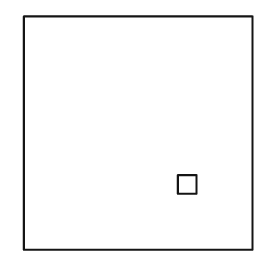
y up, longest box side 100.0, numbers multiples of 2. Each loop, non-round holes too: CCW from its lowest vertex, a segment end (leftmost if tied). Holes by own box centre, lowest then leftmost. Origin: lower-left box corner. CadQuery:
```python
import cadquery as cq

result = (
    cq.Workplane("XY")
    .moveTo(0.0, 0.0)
    .lineTo(98.0, 0.0)
    .lineTo(98.0, 100.0)
    .lineTo(0.0, 100.0)
    .close()
    .moveTo(66.0, 24.0)
    .lineTo(74.0, 24.0)
    .lineTo(74.0, 32.0)
    .lineTo(66.0, 32.0)
    .close()
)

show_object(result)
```